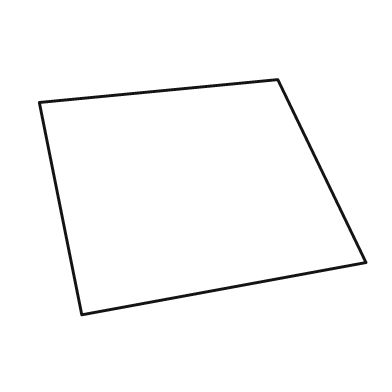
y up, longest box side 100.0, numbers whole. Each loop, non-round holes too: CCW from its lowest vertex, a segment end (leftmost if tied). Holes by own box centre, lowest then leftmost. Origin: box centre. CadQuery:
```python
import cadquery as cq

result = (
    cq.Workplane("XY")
    .moveTo(-37.0, -36.0)
    .lineTo(50.0, -20.0)
    .lineTo(23.0, 36.0)
    .lineTo(-50.0, 29.0)
    .close()
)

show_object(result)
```